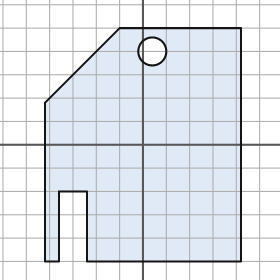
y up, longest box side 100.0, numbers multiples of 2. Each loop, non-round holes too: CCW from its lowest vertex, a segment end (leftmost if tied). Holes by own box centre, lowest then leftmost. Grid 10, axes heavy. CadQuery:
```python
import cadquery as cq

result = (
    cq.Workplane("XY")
    .moveTo(-42.0, -50.0)
    .lineTo(-36.0, -50.0)
    .lineTo(-36.0, -20.0)
    .lineTo(-24.0, -20.0)
    .lineTo(-24.0, -50.0)
    .lineTo(42.0, -50.0)
    .lineTo(42.0, 50.0)
    .lineTo(-10.0, 50.0)
    .lineTo(-42.0, 18.0)
    .close()
    .moveTo(4.0, 40.0)
    .circle(6.0)
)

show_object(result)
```